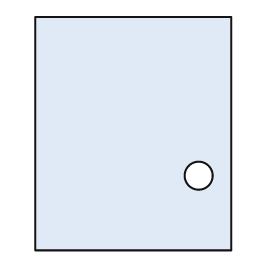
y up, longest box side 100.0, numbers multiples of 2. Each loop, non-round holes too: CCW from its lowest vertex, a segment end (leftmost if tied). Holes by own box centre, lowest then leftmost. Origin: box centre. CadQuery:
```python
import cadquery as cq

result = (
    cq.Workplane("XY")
    .moveTo(-42.0, -50.0)
    .lineTo(42.0, -50.0)
    .lineTo(42.0, 50.0)
    .lineTo(-42.0, 50.0)
    .close()
    .moveTo(28.0, -18.0)
    .circle(6.0)
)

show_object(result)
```